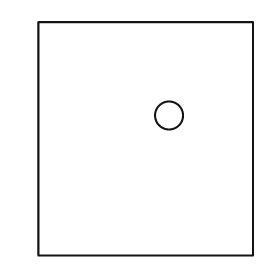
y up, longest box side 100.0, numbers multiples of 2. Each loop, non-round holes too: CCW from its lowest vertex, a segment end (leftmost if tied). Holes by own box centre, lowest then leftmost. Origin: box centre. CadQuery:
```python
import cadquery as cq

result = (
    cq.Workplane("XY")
    .moveTo(-46.0, -50.0)
    .lineTo(46.0, -50.0)
    .lineTo(46.0, 50.0)
    .lineTo(-46.0, 50.0)
    .close()
    .moveTo(10.0, 10.0)
    .circle(6.0)
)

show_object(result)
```